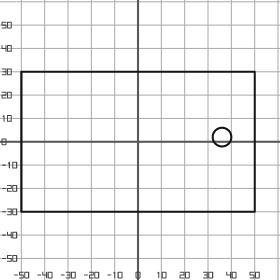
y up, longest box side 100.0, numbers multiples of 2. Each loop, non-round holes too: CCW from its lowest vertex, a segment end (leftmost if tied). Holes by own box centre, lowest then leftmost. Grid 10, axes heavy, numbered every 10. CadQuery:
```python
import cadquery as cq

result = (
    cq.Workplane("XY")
    .moveTo(-50.0, -30.0)
    .lineTo(50.0, -30.0)
    .lineTo(50.0, 30.0)
    .lineTo(-50.0, 30.0)
    .close()
    .moveTo(36.0, 2.0)
    .circle(4.0)
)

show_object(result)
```